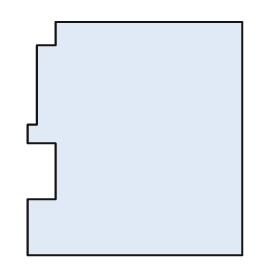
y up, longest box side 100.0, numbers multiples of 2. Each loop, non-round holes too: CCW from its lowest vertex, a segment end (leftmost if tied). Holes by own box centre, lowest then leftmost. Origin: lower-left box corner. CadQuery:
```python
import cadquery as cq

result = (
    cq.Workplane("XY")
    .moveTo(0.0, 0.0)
    .lineTo(92.0, 0.0)
    .lineTo(92.0, 100.0)
    .lineTo(12.0, 100.0)
    .lineTo(12.0, 90.0)
    .lineTo(4.0, 90.0)
    .lineTo(4.0, 56.0)
    .lineTo(0.0, 56.0)
    .lineTo(0.0, 48.0)
    .lineTo(12.0, 48.0)
    .lineTo(12.0, 24.0)
    .lineTo(0.0, 24.0)
    .close()
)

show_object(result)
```